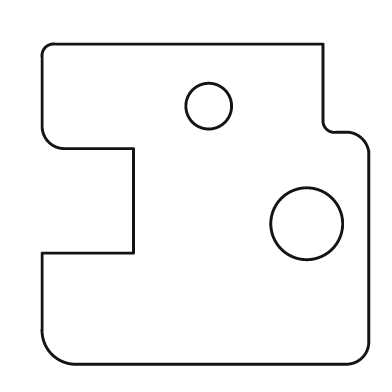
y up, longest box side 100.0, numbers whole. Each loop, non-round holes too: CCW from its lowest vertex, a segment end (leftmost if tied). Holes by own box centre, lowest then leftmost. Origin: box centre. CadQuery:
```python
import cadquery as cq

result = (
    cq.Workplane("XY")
    .moveTo(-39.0, -49.0)
    .lineTo(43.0, -49.0)
    .threePointArc((48.0, -47.0), (50.0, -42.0))
    .lineTo(50.0, 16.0)
    .threePointArc((48.0, 20.0), (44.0, 22.0))
    .lineTo(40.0, 22.0)
    .threePointArc((37.0, 23.0), (36.0, 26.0))
    .lineTo(36.0, 49.0)
    .lineTo(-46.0, 49.0)
    .threePointArc((-49.0, 48.0), (-50.0, 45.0))
    .lineTo(-50.0, 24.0)
    .threePointArc((-48.0, 19.0), (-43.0, 17.0))
    .lineTo(-22.0, 17.0)
    .lineTo(-22.0, -15.0)
    .lineTo(-50.0, -15.0)
    .lineTo(-50.0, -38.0)
    .threePointArc((-47.0, -46.0), (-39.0, -49.0))
    .close()
    .moveTo(31.0, -6.0)
    .circle(11.0)
    .moveTo(1.0, 30.0)
    .circle(7.0)
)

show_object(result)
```